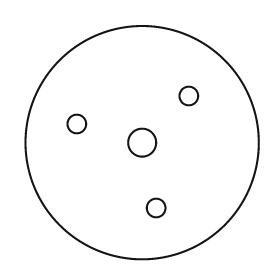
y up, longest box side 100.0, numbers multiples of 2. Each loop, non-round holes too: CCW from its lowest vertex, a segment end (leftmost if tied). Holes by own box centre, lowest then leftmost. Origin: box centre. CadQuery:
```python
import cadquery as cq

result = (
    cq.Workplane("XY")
    .moveTo(0.0, 0.0)
    .circle(50.0)
    .moveTo(6.0, -28.0)
    .circle(4.0)
    .moveTo(0.0, 0.0)
    .circle(6.0)
    .moveTo(-28.0, 8.0)
    .circle(4.0)
    .moveTo(20.0, 20.0)
    .circle(4.0)
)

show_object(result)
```